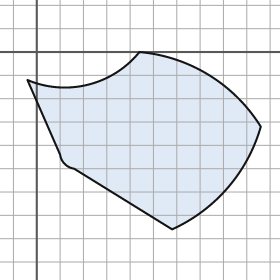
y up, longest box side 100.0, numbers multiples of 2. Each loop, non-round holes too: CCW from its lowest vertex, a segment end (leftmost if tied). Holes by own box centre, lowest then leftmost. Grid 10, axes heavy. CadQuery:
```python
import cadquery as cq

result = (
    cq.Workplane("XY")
    .moveTo(58.0, -76.0)
    .threePointArc((82.0, -58.0), (96.0, -32.0))
    .threePointArc((74.0, -10.0), (44.0, 0.0))
    .threePointArc((22.0, -14.0), (-4.0, -12.0))
    .lineTo(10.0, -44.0)
    .threePointArc((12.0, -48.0), (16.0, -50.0))
    .close()
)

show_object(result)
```